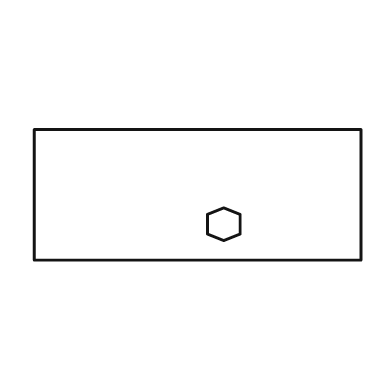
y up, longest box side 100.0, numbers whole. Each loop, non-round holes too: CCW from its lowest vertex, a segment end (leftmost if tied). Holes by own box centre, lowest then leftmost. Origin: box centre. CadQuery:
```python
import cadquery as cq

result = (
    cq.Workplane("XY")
    .moveTo(-50.0, -20.0)
    .lineTo(50.0, -20.0)
    .lineTo(50.0, 20.0)
    .lineTo(-50.0, 20.0)
    .close()
    .moveTo(8.0, -14.0)
    .lineTo(13.0, -12.0)
    .lineTo(13.0, -6.0)
    .lineTo(8.0, -4.0)
    .lineTo(3.0, -6.0)
    .lineTo(3.0, -12.0)
    .close()
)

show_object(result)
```